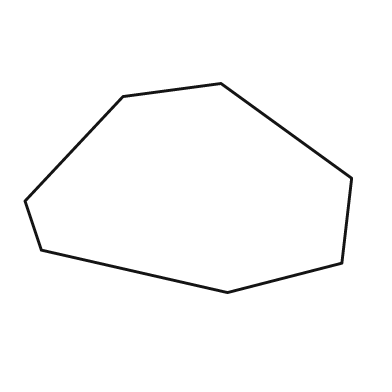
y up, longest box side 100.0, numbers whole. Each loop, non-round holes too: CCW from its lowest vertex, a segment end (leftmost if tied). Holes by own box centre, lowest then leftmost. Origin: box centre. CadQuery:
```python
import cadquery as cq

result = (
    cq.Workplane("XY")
    .moveTo(12.0, -32.0)
    .lineTo(47.0, -23.0)
    .lineTo(50.0, 3.0)
    .lineTo(10.0, 32.0)
    .lineTo(-20.0, 28.0)
    .lineTo(-50.0, -4.0)
    .lineTo(-45.0, -19.0)
    .close()
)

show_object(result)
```